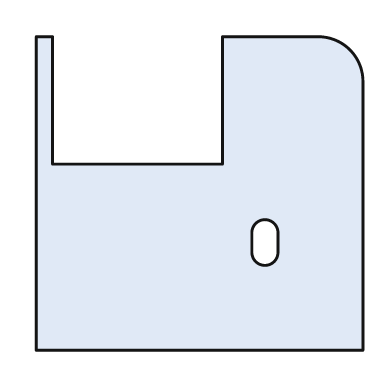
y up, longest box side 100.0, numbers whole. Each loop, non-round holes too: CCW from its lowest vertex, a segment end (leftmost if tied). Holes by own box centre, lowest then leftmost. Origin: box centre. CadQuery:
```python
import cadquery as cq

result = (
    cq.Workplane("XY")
    .moveTo(-50.0, -48.0)
    .lineTo(50.0, -48.0)
    .lineTo(50.0, 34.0)
    .threePointArc((46.0, 44.0), (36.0, 48.0))
    .lineTo(7.0, 48.0)
    .lineTo(7.0, 9.0)
    .lineTo(-45.0, 9.0)
    .lineTo(-45.0, 48.0)
    .lineTo(-50.0, 48.0)
    .close()
    .moveTo(16.0, -18.0)
    .threePointArc((20.0, -22.0), (24.0, -18.0))
    .lineTo(24.0, -12.0)
    .threePointArc((20.0, -8.0), (16.0, -12.0))
    .close()
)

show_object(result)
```